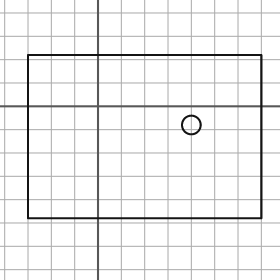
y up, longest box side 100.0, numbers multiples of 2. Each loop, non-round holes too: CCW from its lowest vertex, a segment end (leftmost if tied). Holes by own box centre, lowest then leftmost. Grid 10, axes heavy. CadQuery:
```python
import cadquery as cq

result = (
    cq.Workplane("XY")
    .moveTo(-30.0, -48.0)
    .lineTo(70.0, -48.0)
    .lineTo(70.0, 22.0)
    .lineTo(-30.0, 22.0)
    .close()
    .moveTo(40.0, -8.0)
    .circle(4.0)
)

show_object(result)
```